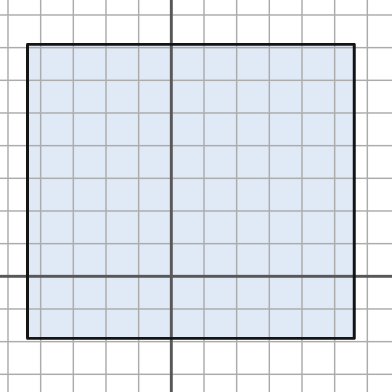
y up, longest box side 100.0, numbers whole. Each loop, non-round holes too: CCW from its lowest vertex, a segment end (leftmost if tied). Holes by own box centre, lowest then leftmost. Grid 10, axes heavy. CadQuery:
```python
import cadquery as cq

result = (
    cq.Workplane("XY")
    .moveTo(-44.0, -19.0)
    .lineTo(56.0, -19.0)
    .lineTo(56.0, 71.0)
    .lineTo(-44.0, 71.0)
    .close()
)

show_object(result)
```